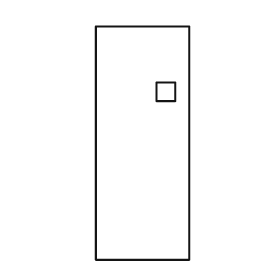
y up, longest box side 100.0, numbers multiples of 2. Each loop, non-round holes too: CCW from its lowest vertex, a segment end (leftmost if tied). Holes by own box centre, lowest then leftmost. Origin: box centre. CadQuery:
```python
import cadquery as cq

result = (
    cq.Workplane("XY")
    .moveTo(-20.0, -50.0)
    .lineTo(20.0, -50.0)
    .lineTo(20.0, 50.0)
    .lineTo(-20.0, 50.0)
    .close()
    .moveTo(6.0, 18.0)
    .lineTo(14.0, 18.0)
    .lineTo(14.0, 26.0)
    .lineTo(6.0, 26.0)
    .close()
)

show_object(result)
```